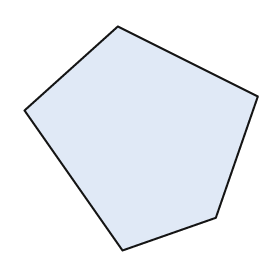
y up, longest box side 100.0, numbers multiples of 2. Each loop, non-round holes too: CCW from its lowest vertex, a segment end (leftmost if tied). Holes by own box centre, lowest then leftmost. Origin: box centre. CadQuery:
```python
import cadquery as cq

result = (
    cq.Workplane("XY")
    .moveTo(-8.0, -48.0)
    .lineTo(32.0, -34.0)
    .lineTo(50.0, 18.0)
    .lineTo(-10.0, 48.0)
    .lineTo(-50.0, 12.0)
    .close()
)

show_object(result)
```